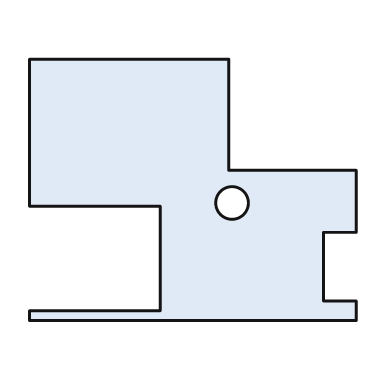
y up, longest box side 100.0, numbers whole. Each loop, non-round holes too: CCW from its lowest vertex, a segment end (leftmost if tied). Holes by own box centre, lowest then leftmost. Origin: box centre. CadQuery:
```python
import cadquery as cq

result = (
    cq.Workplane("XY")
    .moveTo(-50.0, -40.0)
    .lineTo(50.0, -40.0)
    .lineTo(50.0, -34.0)
    .lineTo(40.0, -34.0)
    .lineTo(40.0, -13.0)
    .lineTo(50.0, -13.0)
    .lineTo(50.0, 6.0)
    .lineTo(11.0, 6.0)
    .lineTo(11.0, 40.0)
    .lineTo(-50.0, 40.0)
    .lineTo(-50.0, -5.0)
    .lineTo(-10.0, -5.0)
    .lineTo(-10.0, -37.0)
    .lineTo(-50.0, -37.0)
    .close()
    .moveTo(12.0, -4.0)
    .circle(5.0)
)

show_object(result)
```